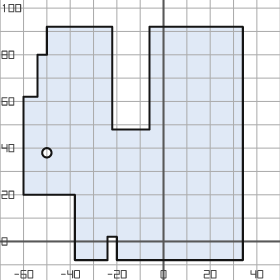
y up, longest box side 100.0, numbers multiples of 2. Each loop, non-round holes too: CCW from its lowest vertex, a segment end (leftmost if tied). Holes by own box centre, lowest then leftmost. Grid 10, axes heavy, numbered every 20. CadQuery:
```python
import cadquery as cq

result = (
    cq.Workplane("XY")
    .moveTo(-38.0, -8.0)
    .lineTo(-24.0, -8.0)
    .lineTo(-24.0, 2.0)
    .lineTo(-20.0, 2.0)
    .lineTo(-20.0, -8.0)
    .lineTo(34.0, -8.0)
    .lineTo(34.0, 92.0)
    .lineTo(-6.0, 92.0)
    .lineTo(-6.0, 48.0)
    .lineTo(-22.0, 48.0)
    .lineTo(-22.0, 92.0)
    .lineTo(-50.0, 92.0)
    .lineTo(-50.0, 80.0)
    .lineTo(-54.0, 80.0)
    .lineTo(-54.0, 62.0)
    .lineTo(-60.0, 62.0)
    .lineTo(-60.0, 20.0)
    .lineTo(-38.0, 20.0)
    .close()
    .moveTo(-50.0, 38.0)
    .circle(2.0)
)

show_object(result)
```